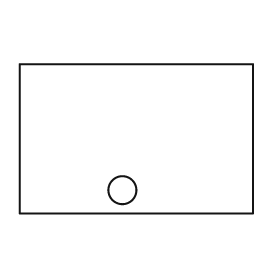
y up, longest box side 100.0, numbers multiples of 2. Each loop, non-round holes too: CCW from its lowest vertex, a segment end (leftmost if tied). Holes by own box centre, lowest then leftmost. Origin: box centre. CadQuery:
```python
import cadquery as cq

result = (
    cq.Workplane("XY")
    .moveTo(-50.0, -32.0)
    .lineTo(50.0, -32.0)
    .lineTo(50.0, 32.0)
    .lineTo(-50.0, 32.0)
    .close()
    .moveTo(-6.0, -22.0)
    .circle(6.0)
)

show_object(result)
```